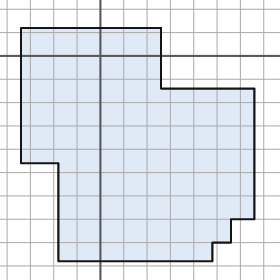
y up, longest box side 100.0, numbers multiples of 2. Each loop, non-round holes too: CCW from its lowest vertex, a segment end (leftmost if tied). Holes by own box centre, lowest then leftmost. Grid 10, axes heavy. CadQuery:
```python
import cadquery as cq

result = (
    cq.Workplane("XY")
    .moveTo(-18.0, -88.0)
    .lineTo(48.0, -88.0)
    .lineTo(48.0, -80.0)
    .lineTo(56.0, -80.0)
    .lineTo(56.0, -70.0)
    .lineTo(66.0, -70.0)
    .lineTo(66.0, -14.0)
    .lineTo(26.0, -14.0)
    .lineTo(26.0, 12.0)
    .lineTo(-34.0, 12.0)
    .lineTo(-34.0, -46.0)
    .lineTo(-18.0, -46.0)
    .close()
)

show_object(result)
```